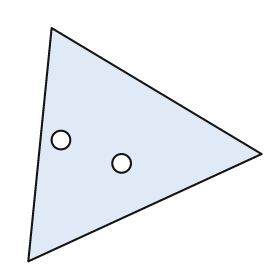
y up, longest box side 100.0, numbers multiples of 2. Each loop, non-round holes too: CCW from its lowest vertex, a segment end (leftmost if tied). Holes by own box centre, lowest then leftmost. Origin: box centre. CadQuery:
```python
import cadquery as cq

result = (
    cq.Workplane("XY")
    .moveTo(-50.0, -50.0)
    .lineTo(50.0, -4.0)
    .lineTo(-40.0, 50.0)
    .close()
    .moveTo(-10.0, -8.0)
    .circle(4.0)
    .moveTo(-36.0, 2.0)
    .circle(4.0)
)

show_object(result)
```